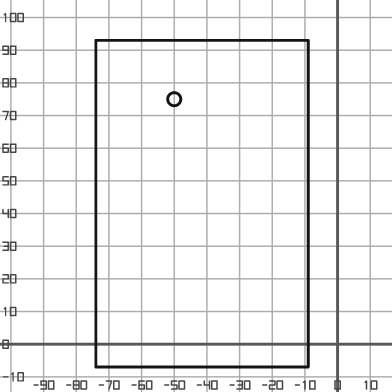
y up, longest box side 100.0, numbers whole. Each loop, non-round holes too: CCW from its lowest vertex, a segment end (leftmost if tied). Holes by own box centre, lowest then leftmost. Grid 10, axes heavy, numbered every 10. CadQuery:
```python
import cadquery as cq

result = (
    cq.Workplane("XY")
    .moveTo(-74.0, -7.0)
    .lineTo(-9.0, -7.0)
    .lineTo(-9.0, 93.0)
    .lineTo(-74.0, 93.0)
    .close()
    .moveTo(-50.0, 75.0)
    .circle(2.0)
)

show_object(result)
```